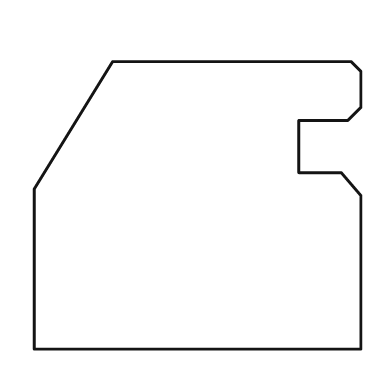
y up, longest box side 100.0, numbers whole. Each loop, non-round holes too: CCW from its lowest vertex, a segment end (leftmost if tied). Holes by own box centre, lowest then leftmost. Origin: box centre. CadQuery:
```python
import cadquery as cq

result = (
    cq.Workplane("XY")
    .moveTo(-50.0, -44.0)
    .lineTo(50.0, -44.0)
    .lineTo(50.0, 3.0)
    .lineTo(44.0, 10.0)
    .lineTo(31.0, 10.0)
    .lineTo(31.0, 26.0)
    .lineTo(46.0, 26.0)
    .lineTo(50.0, 30.0)
    .lineTo(50.0, 41.0)
    .lineTo(47.0, 44.0)
    .lineTo(-26.0, 44.0)
    .lineTo(-50.0, 5.0)
    .close()
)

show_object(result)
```